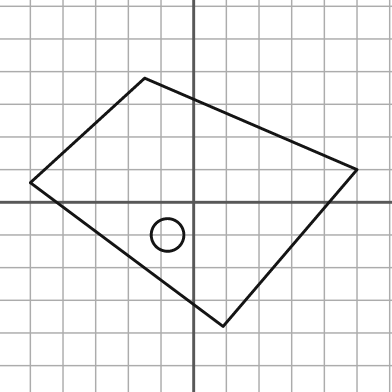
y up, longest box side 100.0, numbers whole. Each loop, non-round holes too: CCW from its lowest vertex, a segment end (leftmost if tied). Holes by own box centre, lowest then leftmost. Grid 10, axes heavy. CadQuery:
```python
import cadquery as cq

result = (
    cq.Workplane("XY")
    .moveTo(9.0, -38.0)
    .lineTo(50.0, 10.0)
    .lineTo(-15.0, 38.0)
    .lineTo(-50.0, 6.0)
    .close()
    .moveTo(-8.0, -10.0)
    .circle(5.0)
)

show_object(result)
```